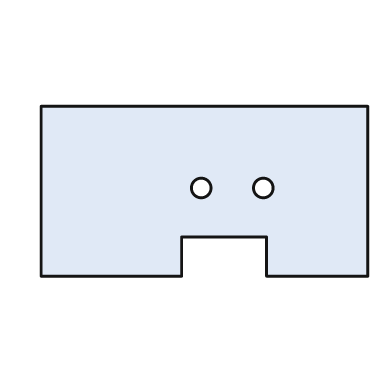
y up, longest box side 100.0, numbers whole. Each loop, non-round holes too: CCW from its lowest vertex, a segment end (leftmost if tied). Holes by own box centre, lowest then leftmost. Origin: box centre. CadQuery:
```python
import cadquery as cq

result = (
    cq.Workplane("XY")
    .moveTo(-50.0, -26.0)
    .lineTo(-7.0, -26.0)
    .lineTo(-7.0, -14.0)
    .lineTo(19.0, -14.0)
    .lineTo(19.0, -26.0)
    .lineTo(50.0, -26.0)
    .lineTo(50.0, 26.0)
    .lineTo(-50.0, 26.0)
    .close()
    .moveTo(-1.0, 1.0)
    .circle(3.0)
    .moveTo(18.0, 1.0)
    .circle(3.0)
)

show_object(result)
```